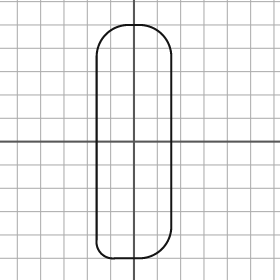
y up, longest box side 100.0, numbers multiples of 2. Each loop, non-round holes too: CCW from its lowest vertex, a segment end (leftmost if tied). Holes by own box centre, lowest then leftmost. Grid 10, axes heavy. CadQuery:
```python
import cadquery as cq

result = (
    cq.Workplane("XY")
    .moveTo(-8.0, -50.0)
    .lineTo(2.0, -50.0)
    .threePointArc((12.0, -46.0), (16.0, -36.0))
    .lineTo(16.0, 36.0)
    .threePointArc((12.0, 46.0), (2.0, 50.0))
    .lineTo(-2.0, 50.0)
    .threePointArc((-12.0, 46.0), (-16.0, 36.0))
    .lineTo(-16.0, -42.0)
    .threePointArc((-14.0, -48.0), (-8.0, -50.0))
    .close()
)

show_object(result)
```